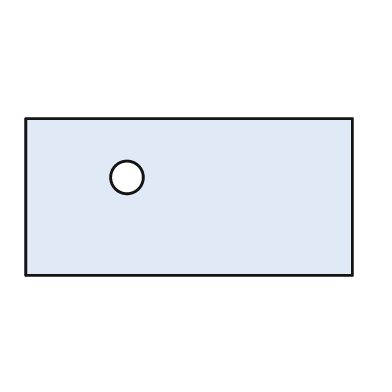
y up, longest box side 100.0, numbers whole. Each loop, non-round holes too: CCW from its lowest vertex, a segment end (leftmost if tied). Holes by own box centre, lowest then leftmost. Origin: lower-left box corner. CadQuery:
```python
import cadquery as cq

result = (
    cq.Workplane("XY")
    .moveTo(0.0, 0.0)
    .lineTo(100.0, 0.0)
    .lineTo(100.0, 48.0)
    .lineTo(0.0, 48.0)
    .close()
    .moveTo(31.0, 30.0)
    .circle(5.0)
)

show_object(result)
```